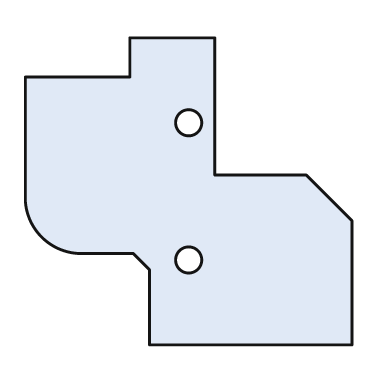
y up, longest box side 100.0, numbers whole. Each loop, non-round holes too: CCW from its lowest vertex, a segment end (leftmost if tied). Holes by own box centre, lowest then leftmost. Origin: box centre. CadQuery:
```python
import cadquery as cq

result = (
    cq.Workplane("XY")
    .moveTo(-12.0, -47.0)
    .lineTo(50.0, -47.0)
    .lineTo(50.0, -9.0)
    .lineTo(36.0, 5.0)
    .lineTo(8.0, 5.0)
    .lineTo(8.0, 47.0)
    .lineTo(-18.0, 47.0)
    .lineTo(-18.0, 35.0)
    .lineTo(-50.0, 35.0)
    .lineTo(-50.0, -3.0)
    .threePointArc((-45.0, -14.0), (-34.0, -19.0))
    .lineTo(-17.0, -19.0)
    .lineTo(-12.0, -24.0)
    .close()
    .moveTo(0.0, -21.0)
    .circle(4.0)
    .moveTo(0.0, 21.0)
    .circle(4.0)
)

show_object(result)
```